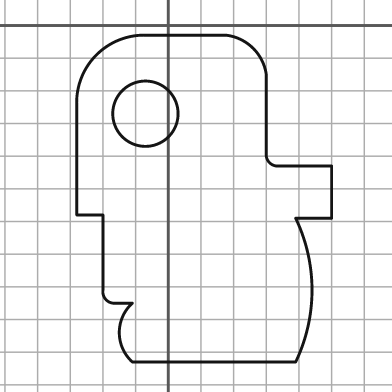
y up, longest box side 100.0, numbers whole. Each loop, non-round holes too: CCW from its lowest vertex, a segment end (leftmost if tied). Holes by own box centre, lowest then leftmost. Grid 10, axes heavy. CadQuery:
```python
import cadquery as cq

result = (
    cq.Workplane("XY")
    .moveTo(-11.0, -103.0)
    .lineTo(39.0, -103.0)
    .threePointArc((44.0, -81.0), (39.0, -59.0))
    .lineTo(50.0, -59.0)
    .lineTo(50.0, -43.0)
    .lineTo(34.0, -43.0)
    .threePointArc((31.0, -42.0), (30.0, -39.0))
    .lineTo(30.0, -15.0)
    .threePointArc((26.0, -7.0), (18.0, -3.0))
    .lineTo(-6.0, -3.0)
    .threePointArc((-22.0, -9.0), (-28.0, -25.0))
    .lineTo(-28.0, -58.0)
    .lineTo(-20.0, -58.0)
    .lineTo(-20.0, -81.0)
    .threePointArc((-19.0, -84.0), (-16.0, -85.0))
    .lineTo(-11.0, -85.0)
    .threePointArc((-15.0, -94.0), (-11.0, -103.0))
    .close()
    .moveTo(-7.0, -27.0)
    .circle(10.0)
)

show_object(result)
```